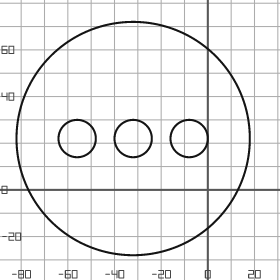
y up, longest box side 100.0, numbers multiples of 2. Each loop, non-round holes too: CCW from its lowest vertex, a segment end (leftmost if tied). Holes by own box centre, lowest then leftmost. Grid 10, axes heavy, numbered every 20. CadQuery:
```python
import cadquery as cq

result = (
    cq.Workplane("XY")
    .moveTo(-32.0, 22.0)
    .circle(50.0)
    .moveTo(-56.0, 22.0)
    .circle(8.0)
    .moveTo(-32.0, 22.0)
    .circle(8.0)
    .moveTo(-8.0, 22.0)
    .circle(8.0)
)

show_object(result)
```